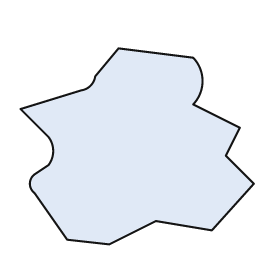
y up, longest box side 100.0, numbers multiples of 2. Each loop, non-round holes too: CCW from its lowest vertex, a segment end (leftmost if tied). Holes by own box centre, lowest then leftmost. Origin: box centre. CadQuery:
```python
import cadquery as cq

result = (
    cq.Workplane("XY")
    .moveTo(-12.0, -42.0)
    .lineTo(8.0, -32.0)
    .lineTo(32.0, -36.0)
    .lineTo(50.0, -16.0)
    .lineTo(38.0, -4.0)
    .lineTo(44.0, 8.0)
    .lineTo(24.0, 18.0)
    .threePointArc((28.0, 28.0), (24.0, 38.0))
    .lineTo(-8.0, 42.0)
    .lineTo(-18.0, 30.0)
    .threePointArc((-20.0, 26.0), (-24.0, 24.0))
    .lineTo(-50.0, 16.0)
    .lineTo(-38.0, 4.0)
    .threePointArc((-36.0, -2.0), (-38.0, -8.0))
    .lineTo(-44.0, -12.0)
    .threePointArc((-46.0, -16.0), (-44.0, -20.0))
    .lineTo(-30.0, -40.0)
    .close()
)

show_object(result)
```